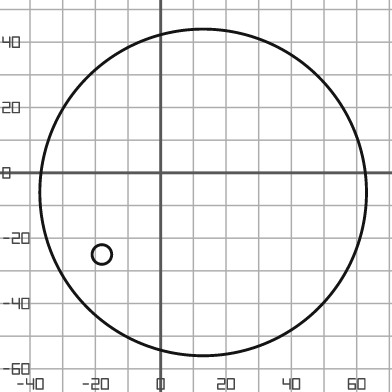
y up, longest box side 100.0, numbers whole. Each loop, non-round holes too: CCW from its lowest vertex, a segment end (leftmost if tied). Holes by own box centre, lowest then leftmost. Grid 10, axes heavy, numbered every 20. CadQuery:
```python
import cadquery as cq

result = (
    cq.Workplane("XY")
    .moveTo(13.0, -6.0)
    .circle(50.0)
    .moveTo(-18.0, -25.0)
    .circle(3.0)
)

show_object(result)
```